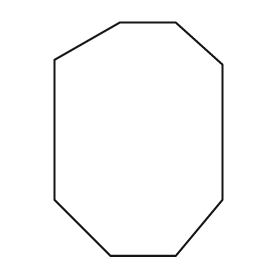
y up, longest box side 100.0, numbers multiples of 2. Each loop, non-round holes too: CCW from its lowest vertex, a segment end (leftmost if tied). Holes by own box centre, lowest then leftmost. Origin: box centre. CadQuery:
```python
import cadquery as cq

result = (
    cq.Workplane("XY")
    .moveTo(-12.0, -50.0)
    .lineTo(16.0, -50.0)
    .lineTo(36.0, -26.0)
    .lineTo(36.0, 32.0)
    .lineTo(16.0, 50.0)
    .lineTo(-8.0, 50.0)
    .lineTo(-36.0, 34.0)
    .lineTo(-36.0, -26.0)
    .close()
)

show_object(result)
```